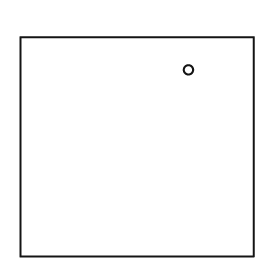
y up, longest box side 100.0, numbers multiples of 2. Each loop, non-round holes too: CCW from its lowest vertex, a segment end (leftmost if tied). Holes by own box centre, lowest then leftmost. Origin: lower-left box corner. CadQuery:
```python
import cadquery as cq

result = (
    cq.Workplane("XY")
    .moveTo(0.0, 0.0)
    .lineTo(100.0, 0.0)
    .lineTo(100.0, 94.0)
    .lineTo(0.0, 94.0)
    .close()
    .moveTo(72.0, 80.0)
    .circle(2.0)
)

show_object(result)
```